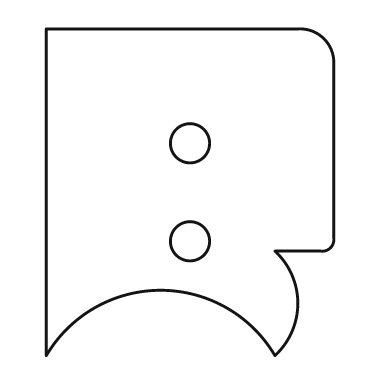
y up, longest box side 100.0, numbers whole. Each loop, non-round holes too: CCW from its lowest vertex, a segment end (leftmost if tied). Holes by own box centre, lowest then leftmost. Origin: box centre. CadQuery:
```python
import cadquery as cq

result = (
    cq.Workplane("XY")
    .moveTo(-44.0, -50.0)
    .threePointArc((-9.0, -30.0), (26.0, -50.0))
    .threePointArc((33.0, -34.0), (26.0, -18.0))
    .lineTo(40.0, -18.0)
    .threePointArc((43.0, -17.0), (44.0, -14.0))
    .lineTo(44.0, 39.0)
    .threePointArc((41.0, 47.0), (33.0, 50.0))
    .lineTo(-44.0, 50.0)
    .close()
    .moveTo(0.0, -15.0)
    .circle(6.0)
    .moveTo(0.0, 15.0)
    .circle(6.0)
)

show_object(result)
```